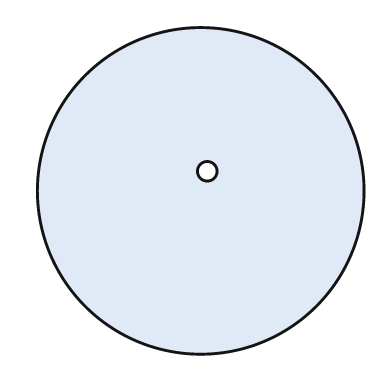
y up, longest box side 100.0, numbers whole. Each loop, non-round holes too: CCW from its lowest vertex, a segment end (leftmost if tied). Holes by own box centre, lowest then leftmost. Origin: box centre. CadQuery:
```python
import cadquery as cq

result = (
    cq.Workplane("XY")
    .moveTo(0.0, 0.0)
    .circle(50.0)
    .moveTo(2.0, 6.0)
    .circle(3.0)
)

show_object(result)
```